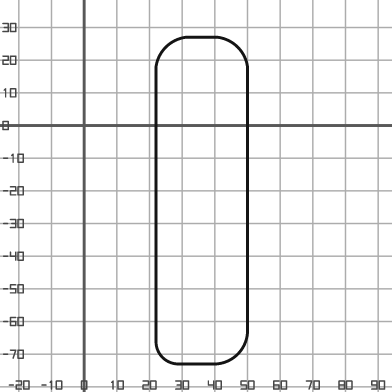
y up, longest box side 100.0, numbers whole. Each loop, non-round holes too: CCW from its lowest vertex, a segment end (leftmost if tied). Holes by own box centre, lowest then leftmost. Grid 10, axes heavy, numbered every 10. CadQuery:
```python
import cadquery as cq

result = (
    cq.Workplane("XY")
    .moveTo(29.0, -73.0)
    .lineTo(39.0, -73.0)
    .threePointArc((47.0, -70.0), (50.0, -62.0))
    .lineTo(50.0, 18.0)
    .threePointArc((47.0, 24.0), (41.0, 27.0))
    .lineTo(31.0, 27.0)
    .threePointArc((25.0, 24.0), (22.0, 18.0))
    .lineTo(22.0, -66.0)
    .threePointArc((24.0, -71.0), (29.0, -73.0))
    .close()
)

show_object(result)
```